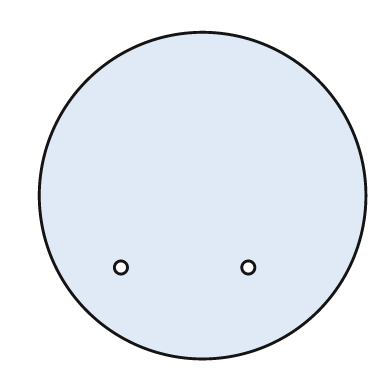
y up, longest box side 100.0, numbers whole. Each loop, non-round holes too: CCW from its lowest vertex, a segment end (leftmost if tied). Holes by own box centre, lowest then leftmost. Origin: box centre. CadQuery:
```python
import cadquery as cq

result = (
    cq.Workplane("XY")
    .moveTo(0.0, 0.0)
    .circle(50.0)
    .moveTo(-25.0, -22.0)
    .circle(2.0)
    .moveTo(14.0, -22.0)
    .circle(2.0)
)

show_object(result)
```